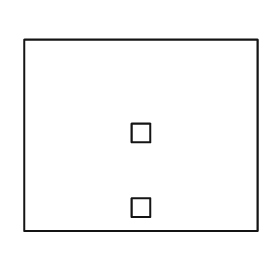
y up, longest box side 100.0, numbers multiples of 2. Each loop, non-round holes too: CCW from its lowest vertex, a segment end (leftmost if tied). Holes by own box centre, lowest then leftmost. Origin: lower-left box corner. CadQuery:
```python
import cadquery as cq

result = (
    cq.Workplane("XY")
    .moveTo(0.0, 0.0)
    .lineTo(100.0, 0.0)
    .lineTo(100.0, 82.0)
    .lineTo(0.0, 82.0)
    .close()
    .moveTo(46.0, 6.0)
    .lineTo(54.0, 6.0)
    .lineTo(54.0, 14.0)
    .lineTo(46.0, 14.0)
    .close()
    .moveTo(46.0, 38.0)
    .lineTo(54.0, 38.0)
    .lineTo(54.0, 46.0)
    .lineTo(46.0, 46.0)
    .close()
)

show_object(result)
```